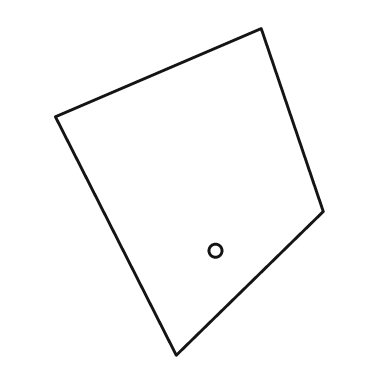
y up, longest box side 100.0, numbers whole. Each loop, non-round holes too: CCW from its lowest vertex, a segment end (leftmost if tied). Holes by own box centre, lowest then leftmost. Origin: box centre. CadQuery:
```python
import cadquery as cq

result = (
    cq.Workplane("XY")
    .moveTo(-4.0, -50.0)
    .lineTo(41.0, -6.0)
    .lineTo(22.0, 50.0)
    .lineTo(-41.0, 23.0)
    .close()
    .moveTo(8.0, -18.0)
    .circle(2.0)
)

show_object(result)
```